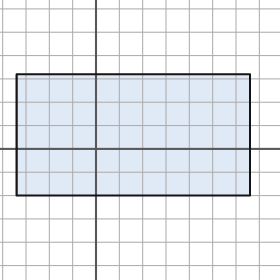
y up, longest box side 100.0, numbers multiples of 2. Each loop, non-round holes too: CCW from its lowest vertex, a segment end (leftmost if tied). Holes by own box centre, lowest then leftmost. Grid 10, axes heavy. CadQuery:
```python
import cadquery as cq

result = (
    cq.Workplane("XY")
    .moveTo(-34.0, -20.0)
    .lineTo(66.0, -20.0)
    .lineTo(66.0, 32.0)
    .lineTo(-34.0, 32.0)
    .close()
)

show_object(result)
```